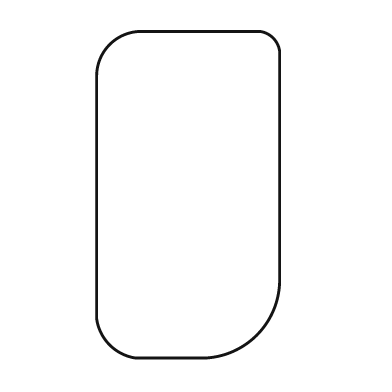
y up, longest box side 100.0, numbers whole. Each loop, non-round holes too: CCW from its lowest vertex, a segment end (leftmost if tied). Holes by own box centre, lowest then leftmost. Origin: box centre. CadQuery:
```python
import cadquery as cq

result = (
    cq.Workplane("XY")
    .moveTo(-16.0, -50.0)
    .lineTo(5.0, -50.0)
    .threePointArc((21.0, -43.0), (28.0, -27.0))
    .lineTo(28.0, 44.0)
    .threePointArc((26.0, 48.0), (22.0, 50.0))
    .lineTo(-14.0, 50.0)
    .threePointArc((-24.0, 46.0), (-28.0, 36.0))
    .lineTo(-28.0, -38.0)
    .threePointArc((-24.0, -46.0), (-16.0, -50.0))
    .close()
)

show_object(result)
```